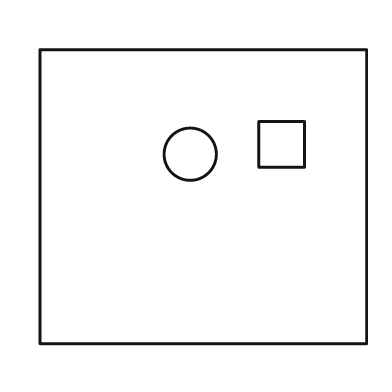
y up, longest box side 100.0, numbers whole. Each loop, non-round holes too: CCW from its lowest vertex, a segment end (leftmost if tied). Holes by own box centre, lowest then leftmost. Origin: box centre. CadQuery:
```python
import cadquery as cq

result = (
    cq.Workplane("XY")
    .moveTo(-50.0, -45.0)
    .lineTo(50.0, -45.0)
    .lineTo(50.0, 45.0)
    .lineTo(-50.0, 45.0)
    .close()
    .moveTo(-4.0, 13.0)
    .circle(8.0)
    .moveTo(17.0, 9.0)
    .lineTo(31.0, 9.0)
    .lineTo(31.0, 23.0)
    .lineTo(17.0, 23.0)
    .close()
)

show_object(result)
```